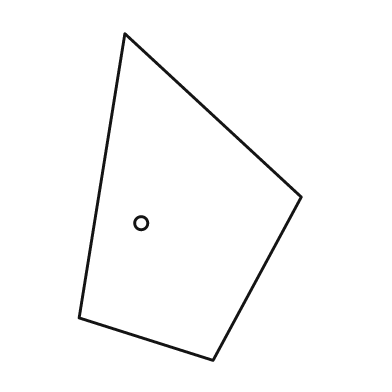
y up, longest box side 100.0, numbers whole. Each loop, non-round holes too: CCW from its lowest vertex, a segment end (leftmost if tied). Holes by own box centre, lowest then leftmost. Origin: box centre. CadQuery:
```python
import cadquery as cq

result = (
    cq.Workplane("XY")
    .moveTo(7.0, -50.0)
    .lineTo(34.0, 0.0)
    .lineTo(-20.0, 50.0)
    .lineTo(-34.0, -37.0)
    .close()
    .moveTo(-15.0, -8.0)
    .circle(2.0)
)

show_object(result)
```